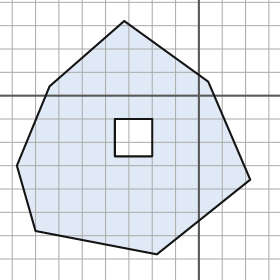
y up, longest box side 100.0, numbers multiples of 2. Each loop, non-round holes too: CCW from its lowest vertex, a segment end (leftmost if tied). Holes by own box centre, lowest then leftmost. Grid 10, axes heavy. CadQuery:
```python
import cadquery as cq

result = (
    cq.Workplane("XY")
    .moveTo(-18.0, -68.0)
    .lineTo(22.0, -36.0)
    .lineTo(4.0, 6.0)
    .lineTo(-32.0, 32.0)
    .lineTo(-64.0, 4.0)
    .lineTo(-78.0, -30.0)
    .lineTo(-70.0, -58.0)
    .close()
    .moveTo(-36.0, -26.0)
    .lineTo(-20.0, -26.0)
    .lineTo(-20.0, -10.0)
    .lineTo(-36.0, -10.0)
    .close()
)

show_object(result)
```